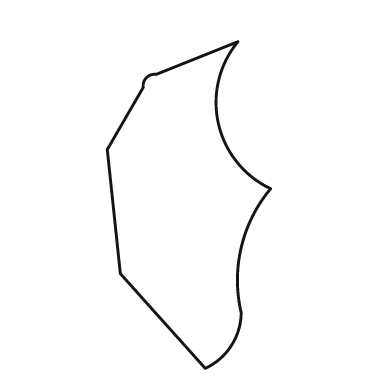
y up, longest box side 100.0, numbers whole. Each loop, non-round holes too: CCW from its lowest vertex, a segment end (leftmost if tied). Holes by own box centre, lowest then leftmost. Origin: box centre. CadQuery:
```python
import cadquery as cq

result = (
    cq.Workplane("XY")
    .moveTo(5.0, -50.0)
    .threePointArc((13.0, -43.0), (16.0, -33.0))
    .threePointArc((16.0, -13.0), (25.0, 5.0))
    .threePointArc((9.0, 25.0), (15.0, 50.0))
    .lineTo(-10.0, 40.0)
    .threePointArc((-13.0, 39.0), (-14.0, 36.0))
    .lineTo(-25.0, 17.0)
    .lineTo(-21.0, -21.0)
    .close()
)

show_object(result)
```